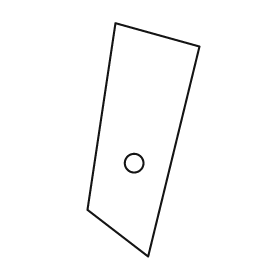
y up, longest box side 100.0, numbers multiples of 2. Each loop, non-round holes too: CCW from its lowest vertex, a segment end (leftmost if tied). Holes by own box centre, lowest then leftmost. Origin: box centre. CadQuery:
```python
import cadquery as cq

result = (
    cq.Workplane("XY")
    .moveTo(2.0, -50.0)
    .lineTo(24.0, 40.0)
    .lineTo(-12.0, 50.0)
    .lineTo(-24.0, -30.0)
    .close()
    .moveTo(-4.0, -10.0)
    .circle(4.0)
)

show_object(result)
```